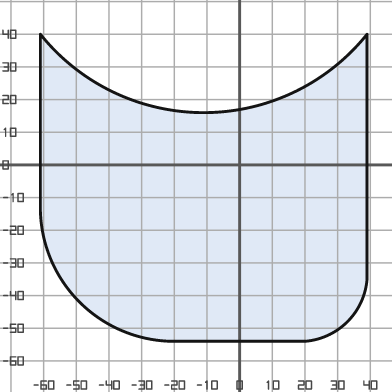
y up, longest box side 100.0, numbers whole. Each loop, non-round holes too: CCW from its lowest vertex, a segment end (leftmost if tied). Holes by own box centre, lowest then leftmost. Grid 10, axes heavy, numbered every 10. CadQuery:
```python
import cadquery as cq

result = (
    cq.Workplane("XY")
    .moveTo(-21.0, -54.0)
    .lineTo(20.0, -54.0)
    .threePointArc((33.0, -48.0), (39.0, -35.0))
    .lineTo(39.0, 40.0)
    .threePointArc((-11.0, 16.0), (-61.0, 40.0))
    .lineTo(-61.0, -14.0)
    .threePointArc((-49.0, -42.0), (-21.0, -54.0))
    .close()
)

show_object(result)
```